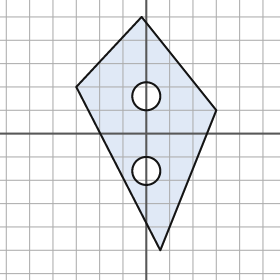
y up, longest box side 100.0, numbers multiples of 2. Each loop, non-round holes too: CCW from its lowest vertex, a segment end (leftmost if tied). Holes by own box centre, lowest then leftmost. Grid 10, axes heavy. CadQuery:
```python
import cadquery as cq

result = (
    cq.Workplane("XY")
    .moveTo(6.0, -50.0)
    .lineTo(30.0, 10.0)
    .lineTo(-2.0, 50.0)
    .lineTo(-30.0, 20.0)
    .close()
    .moveTo(0.0, -16.0)
    .circle(6.0)
    .moveTo(0.0, 16.0)
    .circle(6.0)
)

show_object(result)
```